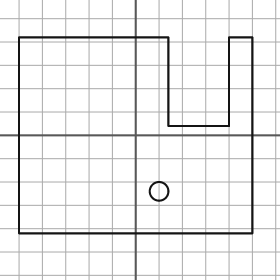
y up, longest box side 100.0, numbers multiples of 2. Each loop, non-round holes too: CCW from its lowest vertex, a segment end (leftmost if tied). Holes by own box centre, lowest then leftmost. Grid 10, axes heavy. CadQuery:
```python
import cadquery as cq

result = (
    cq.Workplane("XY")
    .moveTo(-50.0, -42.0)
    .lineTo(50.0, -42.0)
    .lineTo(50.0, 42.0)
    .lineTo(40.0, 42.0)
    .lineTo(40.0, 4.0)
    .lineTo(14.0, 4.0)
    .lineTo(14.0, 42.0)
    .lineTo(-50.0, 42.0)
    .close()
    .moveTo(10.0, -24.0)
    .circle(4.0)
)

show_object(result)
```